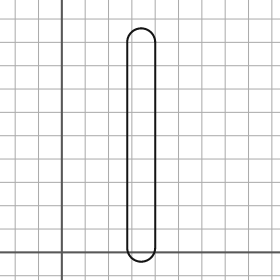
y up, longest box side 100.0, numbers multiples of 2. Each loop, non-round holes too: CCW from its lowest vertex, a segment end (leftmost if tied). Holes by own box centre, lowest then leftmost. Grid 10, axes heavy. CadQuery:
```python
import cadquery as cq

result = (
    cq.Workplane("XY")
    .moveTo(28.0, 2.0)
    .threePointArc((34.0, -4.0), (40.0, 2.0))
    .lineTo(40.0, 90.0)
    .threePointArc((34.0, 96.0), (28.0, 90.0))
    .close()
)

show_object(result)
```